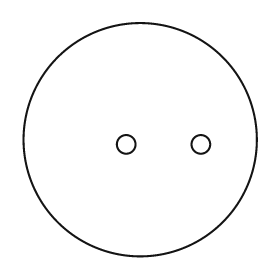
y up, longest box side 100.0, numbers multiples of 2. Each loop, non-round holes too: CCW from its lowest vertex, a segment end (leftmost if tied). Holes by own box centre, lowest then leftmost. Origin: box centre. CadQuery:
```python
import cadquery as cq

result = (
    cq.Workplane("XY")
    .moveTo(0.0, 0.0)
    .circle(50.0)
    .moveTo(-6.0, -2.0)
    .circle(4.0)
    .moveTo(26.0, -2.0)
    .circle(4.0)
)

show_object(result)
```